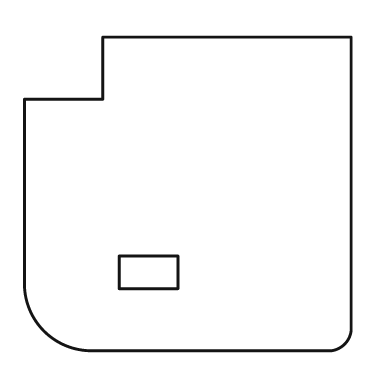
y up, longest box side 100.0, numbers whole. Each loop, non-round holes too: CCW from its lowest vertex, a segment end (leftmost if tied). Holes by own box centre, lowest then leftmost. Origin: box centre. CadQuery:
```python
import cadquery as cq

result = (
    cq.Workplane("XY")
    .moveTo(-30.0, -48.0)
    .lineTo(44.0, -48.0)
    .threePointArc((48.0, -46.0), (50.0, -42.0))
    .lineTo(50.0, 48.0)
    .lineTo(-26.0, 48.0)
    .lineTo(-26.0, 29.0)
    .lineTo(-50.0, 29.0)
    .lineTo(-50.0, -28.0)
    .threePointArc((-44.0, -42.0), (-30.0, -48.0))
    .close()
    .moveTo(-21.0, -29.0)
    .lineTo(-3.0, -29.0)
    .lineTo(-3.0, -19.0)
    .lineTo(-21.0, -19.0)
    .close()
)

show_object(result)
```